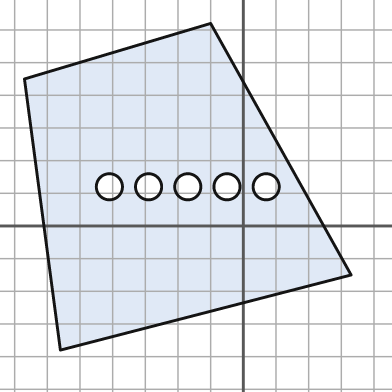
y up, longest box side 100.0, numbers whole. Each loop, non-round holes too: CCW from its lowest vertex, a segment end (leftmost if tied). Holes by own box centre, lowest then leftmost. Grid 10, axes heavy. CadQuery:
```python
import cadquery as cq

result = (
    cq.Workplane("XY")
    .moveTo(-56.0, -38.0)
    .lineTo(33.0, -15.0)
    .lineTo(-10.0, 62.0)
    .lineTo(-67.0, 45.0)
    .close()
    .moveTo(-41.0, 12.0)
    .circle(4.0)
    .moveTo(-29.0, 12.0)
    .circle(4.0)
    .moveTo(-17.0, 12.0)
    .circle(4.0)
    .moveTo(-5.0, 12.0)
    .circle(4.0)
    .moveTo(7.0, 12.0)
    .circle(4.0)
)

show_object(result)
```